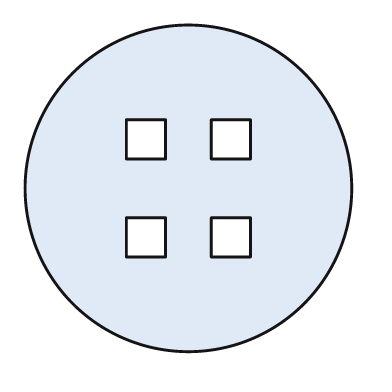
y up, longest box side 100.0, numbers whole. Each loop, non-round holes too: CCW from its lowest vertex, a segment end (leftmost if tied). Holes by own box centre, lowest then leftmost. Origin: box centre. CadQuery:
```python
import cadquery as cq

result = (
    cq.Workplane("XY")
    .moveTo(0.0, 0.0)
    .circle(50.0)
    .moveTo(-19.0, -21.0)
    .lineTo(-7.0, -21.0)
    .lineTo(-7.0, -9.0)
    .lineTo(-19.0, -9.0)
    .close()
    .moveTo(7.0, -21.0)
    .lineTo(19.0, -21.0)
    .lineTo(19.0, -9.0)
    .lineTo(7.0, -9.0)
    .close()
    .moveTo(-19.0, 9.0)
    .lineTo(-7.0, 9.0)
    .lineTo(-7.0, 21.0)
    .lineTo(-19.0, 21.0)
    .close()
    .moveTo(7.0, 9.0)
    .lineTo(19.0, 9.0)
    .lineTo(19.0, 21.0)
    .lineTo(7.0, 21.0)
    .close()
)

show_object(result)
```